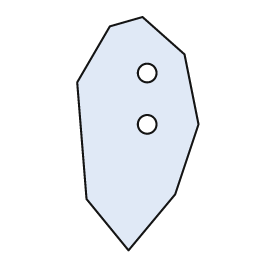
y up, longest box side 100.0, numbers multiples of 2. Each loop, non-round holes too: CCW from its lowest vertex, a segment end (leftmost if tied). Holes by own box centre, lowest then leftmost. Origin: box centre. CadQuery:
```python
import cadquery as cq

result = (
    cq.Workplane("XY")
    .moveTo(-4.0, -50.0)
    .lineTo(16.0, -26.0)
    .lineTo(26.0, 4.0)
    .lineTo(20.0, 34.0)
    .lineTo(2.0, 50.0)
    .lineTo(-12.0, 46.0)
    .lineTo(-26.0, 22.0)
    .lineTo(-22.0, -28.0)
    .close()
    .moveTo(4.0, 4.0)
    .circle(4.0)
    .moveTo(4.0, 26.0)
    .circle(4.0)
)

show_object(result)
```